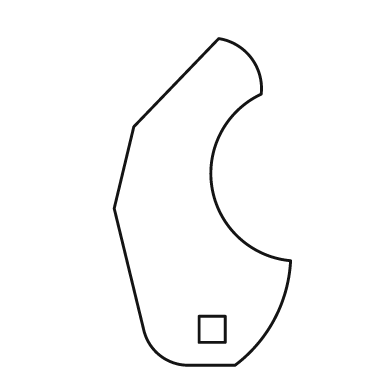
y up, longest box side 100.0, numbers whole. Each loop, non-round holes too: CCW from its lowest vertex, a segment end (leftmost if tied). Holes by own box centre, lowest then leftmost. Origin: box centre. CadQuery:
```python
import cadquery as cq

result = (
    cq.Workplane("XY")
    .moveTo(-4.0, -50.0)
    .lineTo(10.0, -50.0)
    .threePointArc((22.0, -36.0), (27.0, -18.0))
    .threePointArc((3.0, 4.0), (18.0, 33.0))
    .threePointArc((15.0, 44.0), (5.0, 50.0))
    .lineTo(-21.0, 23.0)
    .lineTo(-27.0, -2.0)
    .lineTo(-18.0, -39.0)
    .threePointArc((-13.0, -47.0), (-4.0, -50.0))
    .close()
    .moveTo(-1.0, -43.0)
    .lineTo(7.0, -43.0)
    .lineTo(7.0, -35.0)
    .lineTo(-1.0, -35.0)
    .close()
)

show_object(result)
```